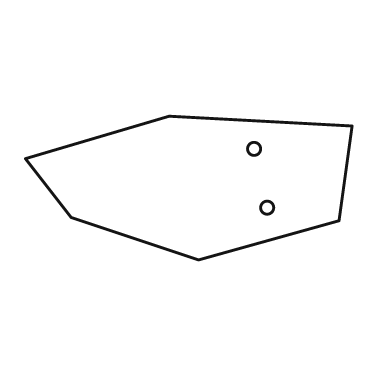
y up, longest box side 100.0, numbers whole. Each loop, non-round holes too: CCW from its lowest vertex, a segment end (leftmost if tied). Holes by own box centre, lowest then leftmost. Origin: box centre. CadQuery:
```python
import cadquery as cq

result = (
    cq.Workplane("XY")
    .moveTo(3.0, -22.0)
    .lineTo(46.0, -10.0)
    .lineTo(50.0, 19.0)
    .lineTo(-6.0, 22.0)
    .lineTo(-50.0, 9.0)
    .lineTo(-36.0, -9.0)
    .close()
    .moveTo(24.0, -6.0)
    .circle(2.0)
    .moveTo(20.0, 12.0)
    .circle(2.0)
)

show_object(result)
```